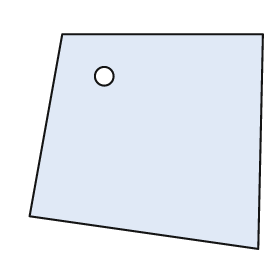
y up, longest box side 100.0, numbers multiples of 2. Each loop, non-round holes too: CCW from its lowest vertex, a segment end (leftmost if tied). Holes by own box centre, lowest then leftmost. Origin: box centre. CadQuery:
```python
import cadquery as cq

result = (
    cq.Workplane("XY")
    .moveTo(48.0, -46.0)
    .lineTo(50.0, 46.0)
    .lineTo(-36.0, 46.0)
    .lineTo(-50.0, -32.0)
    .close()
    .moveTo(-18.0, 28.0)
    .circle(4.0)
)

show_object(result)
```